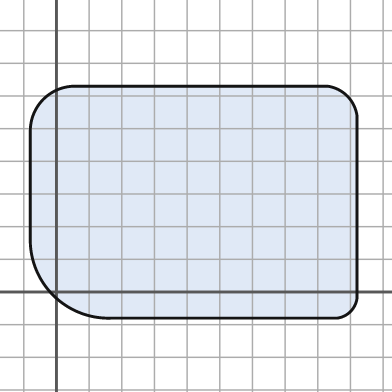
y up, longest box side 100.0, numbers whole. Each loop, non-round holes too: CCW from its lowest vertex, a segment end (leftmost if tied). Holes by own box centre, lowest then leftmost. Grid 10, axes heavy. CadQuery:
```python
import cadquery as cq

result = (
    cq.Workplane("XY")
    .moveTo(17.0, -8.0)
    .lineTo(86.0, -8.0)
    .threePointArc((90.0, -6.0), (92.0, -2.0))
    .lineTo(92.0, 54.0)
    .threePointArc((89.0, 60.0), (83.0, 63.0))
    .lineTo(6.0, 63.0)
    .threePointArc((-4.0, 59.0), (-8.0, 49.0))
    .lineTo(-8.0, 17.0)
    .threePointArc((-1.0, -1.0), (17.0, -8.0))
    .close()
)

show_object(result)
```